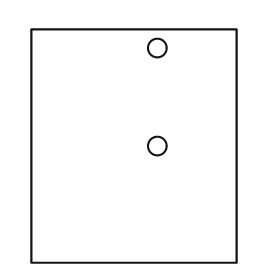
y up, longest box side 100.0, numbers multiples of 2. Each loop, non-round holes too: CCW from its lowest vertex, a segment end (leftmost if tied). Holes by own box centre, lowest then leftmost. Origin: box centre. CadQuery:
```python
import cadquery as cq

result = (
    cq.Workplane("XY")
    .moveTo(-44.0, -50.0)
    .lineTo(44.0, -50.0)
    .lineTo(44.0, 50.0)
    .lineTo(-44.0, 50.0)
    .close()
    .moveTo(10.0, 0.0)
    .circle(4.0)
    .moveTo(10.0, 42.0)
    .circle(4.0)
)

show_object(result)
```